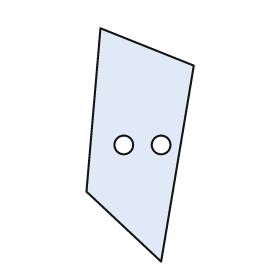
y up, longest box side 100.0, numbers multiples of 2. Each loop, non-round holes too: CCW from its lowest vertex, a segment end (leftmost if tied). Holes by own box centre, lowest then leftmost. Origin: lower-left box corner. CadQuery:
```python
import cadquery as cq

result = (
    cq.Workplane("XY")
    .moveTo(32.0, 0.0)
    .lineTo(46.0, 84.0)
    .lineTo(6.0, 100.0)
    .lineTo(0.0, 30.0)
    .close()
    .moveTo(16.0, 50.0)
    .circle(4.0)
    .moveTo(32.0, 50.0)
    .circle(4.0)
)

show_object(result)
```